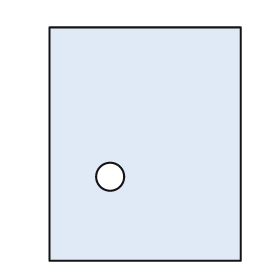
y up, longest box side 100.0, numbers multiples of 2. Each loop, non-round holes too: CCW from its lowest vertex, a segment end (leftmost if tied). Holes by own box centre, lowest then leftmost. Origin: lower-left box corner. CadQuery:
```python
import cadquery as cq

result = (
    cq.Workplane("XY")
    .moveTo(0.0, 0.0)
    .lineTo(82.0, 0.0)
    .lineTo(82.0, 100.0)
    .lineTo(0.0, 100.0)
    .close()
    .moveTo(26.0, 36.0)
    .circle(6.0)
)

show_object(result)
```